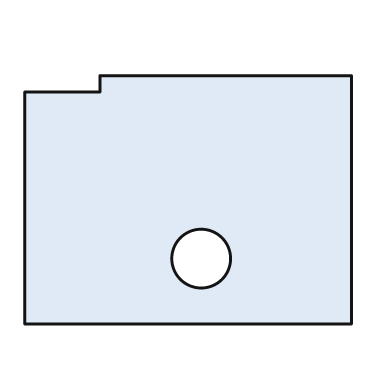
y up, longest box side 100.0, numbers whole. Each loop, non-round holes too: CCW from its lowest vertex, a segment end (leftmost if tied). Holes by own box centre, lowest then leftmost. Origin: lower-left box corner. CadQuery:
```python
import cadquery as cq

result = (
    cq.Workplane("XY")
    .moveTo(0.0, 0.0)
    .lineTo(100.0, 0.0)
    .lineTo(100.0, 76.0)
    .lineTo(23.0, 76.0)
    .lineTo(23.0, 71.0)
    .lineTo(0.0, 71.0)
    .close()
    .moveTo(54.0, 20.0)
    .circle(9.0)
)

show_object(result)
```